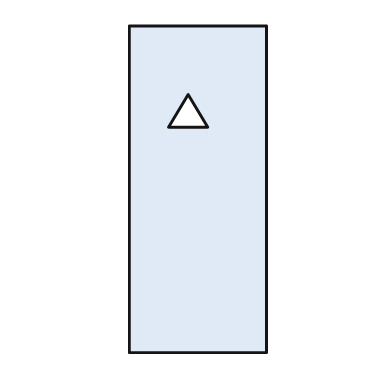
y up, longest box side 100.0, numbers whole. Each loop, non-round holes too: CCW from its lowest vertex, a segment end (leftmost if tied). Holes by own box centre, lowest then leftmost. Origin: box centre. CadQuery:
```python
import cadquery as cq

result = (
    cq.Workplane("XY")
    .moveTo(-21.0, -50.0)
    .lineTo(21.0, -50.0)
    .lineTo(21.0, 50.0)
    .lineTo(-21.0, 50.0)
    .close()
    .moveTo(-9.0, 19.0)
    .lineTo(3.0, 19.0)
    .lineTo(-3.0, 29.0)
    .close()
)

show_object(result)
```